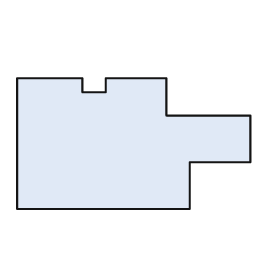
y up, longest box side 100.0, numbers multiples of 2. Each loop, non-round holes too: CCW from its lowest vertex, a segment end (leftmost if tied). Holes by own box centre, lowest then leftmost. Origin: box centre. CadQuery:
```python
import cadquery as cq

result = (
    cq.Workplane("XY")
    .moveTo(-50.0, -28.0)
    .lineTo(24.0, -28.0)
    .lineTo(24.0, -8.0)
    .lineTo(50.0, -8.0)
    .lineTo(50.0, 12.0)
    .lineTo(14.0, 12.0)
    .lineTo(14.0, 28.0)
    .lineTo(-12.0, 28.0)
    .lineTo(-12.0, 22.0)
    .lineTo(-22.0, 22.0)
    .lineTo(-22.0, 28.0)
    .lineTo(-50.0, 28.0)
    .close()
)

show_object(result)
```